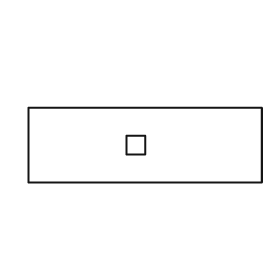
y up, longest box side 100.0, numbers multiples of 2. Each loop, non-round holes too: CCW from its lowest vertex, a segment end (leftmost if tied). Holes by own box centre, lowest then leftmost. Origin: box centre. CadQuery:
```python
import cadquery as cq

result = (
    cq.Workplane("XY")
    .moveTo(-50.0, -16.0)
    .lineTo(50.0, -16.0)
    .lineTo(50.0, 16.0)
    .lineTo(-50.0, 16.0)
    .close()
    .moveTo(-8.0, -4.0)
    .lineTo(0.0, -4.0)
    .lineTo(0.0, 4.0)
    .lineTo(-8.0, 4.0)
    .close()
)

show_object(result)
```